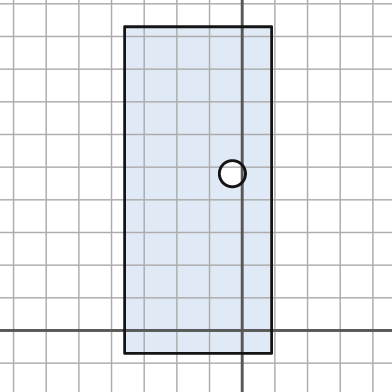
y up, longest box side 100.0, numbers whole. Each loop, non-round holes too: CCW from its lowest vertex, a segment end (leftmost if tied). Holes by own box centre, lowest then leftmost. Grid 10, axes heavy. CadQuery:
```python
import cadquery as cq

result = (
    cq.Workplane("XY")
    .moveTo(-36.0, -7.0)
    .lineTo(9.0, -7.0)
    .lineTo(9.0, 93.0)
    .lineTo(-36.0, 93.0)
    .close()
    .moveTo(-3.0, 48.0)
    .circle(4.0)
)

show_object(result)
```